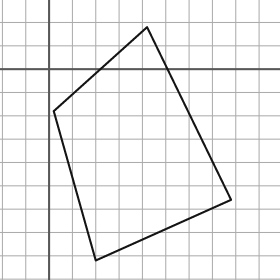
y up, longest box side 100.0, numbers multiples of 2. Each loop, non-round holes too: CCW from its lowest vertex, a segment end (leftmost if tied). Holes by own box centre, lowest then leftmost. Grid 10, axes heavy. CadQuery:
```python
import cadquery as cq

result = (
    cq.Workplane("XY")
    .moveTo(20.0, -82.0)
    .lineTo(78.0, -56.0)
    .lineTo(42.0, 18.0)
    .lineTo(2.0, -18.0)
    .close()
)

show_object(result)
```